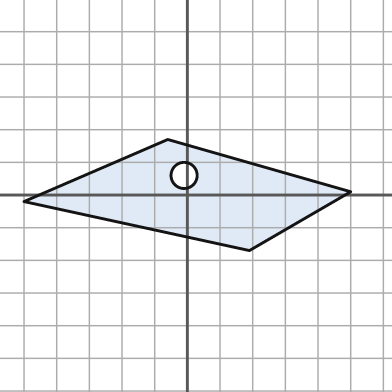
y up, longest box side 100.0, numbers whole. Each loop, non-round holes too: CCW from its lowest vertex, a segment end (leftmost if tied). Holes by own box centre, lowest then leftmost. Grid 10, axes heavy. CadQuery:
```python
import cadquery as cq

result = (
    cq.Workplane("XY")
    .moveTo(19.0, -17.0)
    .lineTo(50.0, 1.0)
    .lineTo(-6.0, 17.0)
    .lineTo(-50.0, -2.0)
    .close()
    .moveTo(-1.0, 6.0)
    .circle(4.0)
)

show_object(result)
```